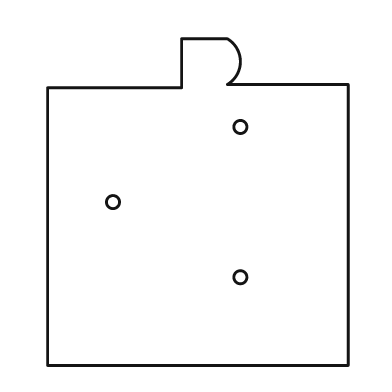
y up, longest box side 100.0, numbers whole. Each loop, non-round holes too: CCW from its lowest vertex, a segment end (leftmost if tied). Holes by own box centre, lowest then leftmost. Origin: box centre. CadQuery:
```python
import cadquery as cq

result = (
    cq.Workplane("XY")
    .moveTo(-46.0, -50.0)
    .lineTo(46.0, -50.0)
    .lineTo(46.0, 36.0)
    .lineTo(9.0, 36.0)
    .threePointArc((13.0, 43.0), (9.0, 50.0))
    .lineTo(-5.0, 50.0)
    .lineTo(-5.0, 35.0)
    .lineTo(-46.0, 35.0)
    .close()
    .moveTo(13.0, -23.0)
    .circle(2.0)
    .moveTo(-26.0, 0.0)
    .circle(2.0)
    .moveTo(13.0, 23.0)
    .circle(2.0)
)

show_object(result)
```